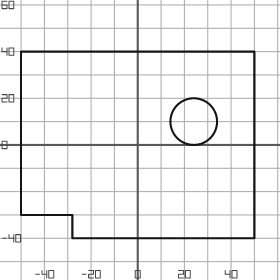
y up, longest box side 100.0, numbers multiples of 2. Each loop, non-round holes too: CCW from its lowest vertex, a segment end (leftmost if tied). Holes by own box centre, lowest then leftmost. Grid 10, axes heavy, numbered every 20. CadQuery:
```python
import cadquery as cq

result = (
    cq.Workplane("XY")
    .moveTo(-28.0, -40.0)
    .lineTo(50.0, -40.0)
    .lineTo(50.0, 40.0)
    .lineTo(-50.0, 40.0)
    .lineTo(-50.0, -30.0)
    .lineTo(-28.0, -30.0)
    .close()
    .moveTo(24.0, 10.0)
    .circle(10.0)
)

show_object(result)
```